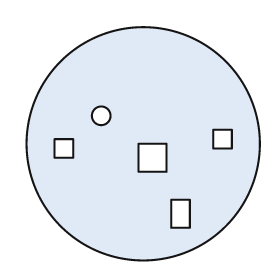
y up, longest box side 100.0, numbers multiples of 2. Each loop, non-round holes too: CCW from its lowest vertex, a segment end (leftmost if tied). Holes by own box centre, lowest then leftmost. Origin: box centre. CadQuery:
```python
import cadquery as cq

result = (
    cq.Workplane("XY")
    .moveTo(0.0, 0.0)
    .circle(50.0)
    .moveTo(12.0, -36.0)
    .lineTo(20.0, -36.0)
    .lineTo(20.0, -24.0)
    .lineTo(12.0, -24.0)
    .close()
    .moveTo(-2.0, -12.0)
    .lineTo(10.0, -12.0)
    .lineTo(10.0, 0.0)
    .lineTo(-2.0, 0.0)
    .close()
    .moveTo(-38.0, -6.0)
    .lineTo(-30.0, -6.0)
    .lineTo(-30.0, 2.0)
    .lineTo(-38.0, 2.0)
    .close()
    .moveTo(30.0, -2.0)
    .lineTo(38.0, -2.0)
    .lineTo(38.0, 6.0)
    .lineTo(30.0, 6.0)
    .close()
    .moveTo(-18.0, 12.0)
    .circle(4.0)
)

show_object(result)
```